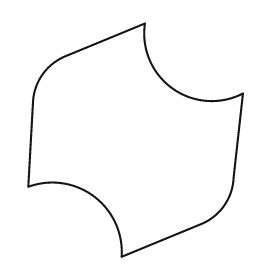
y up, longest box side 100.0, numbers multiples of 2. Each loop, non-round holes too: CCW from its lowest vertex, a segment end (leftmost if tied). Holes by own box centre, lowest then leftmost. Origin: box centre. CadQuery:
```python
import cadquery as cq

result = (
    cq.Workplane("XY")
    .moveTo(-6.0, -50.0)
    .lineTo(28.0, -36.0)
    .threePointArc((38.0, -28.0), (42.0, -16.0))
    .lineTo(46.0, 20.0)
    .threePointArc((16.0, 22.0), (4.0, 50.0))
    .lineTo(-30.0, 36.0)
    .threePointArc((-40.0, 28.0), (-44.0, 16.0))
    .lineTo(-46.0, -20.0)
    .threePointArc((-18.0, -24.0), (-6.0, -50.0))
    .close()
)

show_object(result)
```